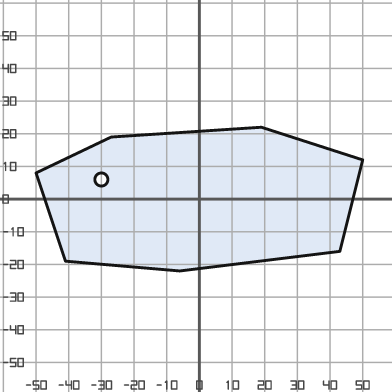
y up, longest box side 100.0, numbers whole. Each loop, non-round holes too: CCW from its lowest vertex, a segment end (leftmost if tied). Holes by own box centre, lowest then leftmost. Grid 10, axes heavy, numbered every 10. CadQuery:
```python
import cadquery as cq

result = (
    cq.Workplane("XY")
    .moveTo(-6.0, -22.0)
    .lineTo(43.0, -16.0)
    .lineTo(50.0, 12.0)
    .lineTo(19.0, 22.0)
    .lineTo(-27.0, 19.0)
    .lineTo(-50.0, 8.0)
    .lineTo(-41.0, -19.0)
    .close()
    .moveTo(-30.0, 6.0)
    .circle(2.0)
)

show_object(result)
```